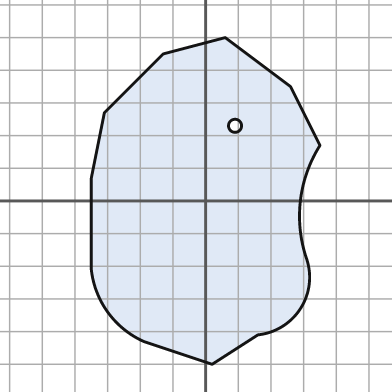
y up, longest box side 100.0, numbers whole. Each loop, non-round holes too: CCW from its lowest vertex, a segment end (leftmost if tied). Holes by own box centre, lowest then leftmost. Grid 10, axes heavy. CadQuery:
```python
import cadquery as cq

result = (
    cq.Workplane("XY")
    .moveTo(2.0, -50.0)
    .lineTo(16.0, -41.0)
    .threePointArc((29.0, -33.0), (31.0, -18.0))
    .threePointArc((29.0, 0.0), (35.0, 17.0))
    .lineTo(26.0, 35.0)
    .lineTo(6.0, 50.0)
    .lineTo(-13.0, 45.0)
    .lineTo(-31.0, 27.0)
    .lineTo(-35.0, 7.0)
    .lineTo(-35.0, -21.0)
    .threePointArc((-30.0, -34.0), (-19.0, -43.0))
    .close()
    .moveTo(9.0, 23.0)
    .circle(2.0)
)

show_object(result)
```